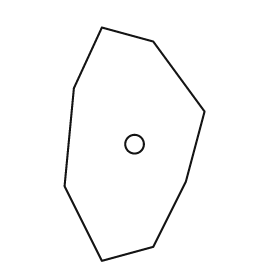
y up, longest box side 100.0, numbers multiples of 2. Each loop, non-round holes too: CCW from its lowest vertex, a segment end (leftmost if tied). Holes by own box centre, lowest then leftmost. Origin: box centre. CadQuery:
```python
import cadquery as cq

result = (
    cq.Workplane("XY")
    .moveTo(-14.0, -50.0)
    .lineTo(8.0, -44.0)
    .lineTo(22.0, -16.0)
    .lineTo(30.0, 14.0)
    .lineTo(8.0, 44.0)
    .lineTo(-14.0, 50.0)
    .lineTo(-26.0, 24.0)
    .lineTo(-30.0, -18.0)
    .close()
    .moveTo(0.0, 0.0)
    .circle(4.0)
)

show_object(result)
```